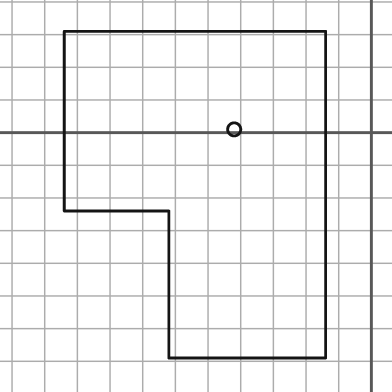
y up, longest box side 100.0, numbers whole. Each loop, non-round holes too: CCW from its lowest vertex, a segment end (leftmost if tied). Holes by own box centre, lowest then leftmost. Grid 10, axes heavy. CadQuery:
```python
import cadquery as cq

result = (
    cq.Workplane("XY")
    .moveTo(-62.0, -69.0)
    .lineTo(-14.0, -69.0)
    .lineTo(-14.0, 31.0)
    .lineTo(-94.0, 31.0)
    .lineTo(-94.0, -24.0)
    .lineTo(-62.0, -24.0)
    .close()
    .moveTo(-42.0, 1.0)
    .circle(2.0)
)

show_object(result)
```